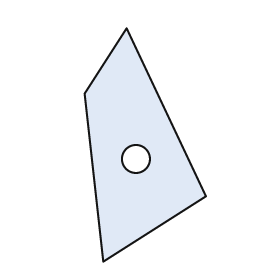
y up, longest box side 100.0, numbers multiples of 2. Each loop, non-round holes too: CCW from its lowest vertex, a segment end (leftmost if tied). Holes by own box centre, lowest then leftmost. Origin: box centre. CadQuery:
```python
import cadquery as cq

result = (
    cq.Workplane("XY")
    .moveTo(-18.0, -50.0)
    .lineTo(26.0, -22.0)
    .lineTo(-8.0, 50.0)
    .lineTo(-26.0, 22.0)
    .close()
    .moveTo(-4.0, -6.0)
    .circle(6.0)
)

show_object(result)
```